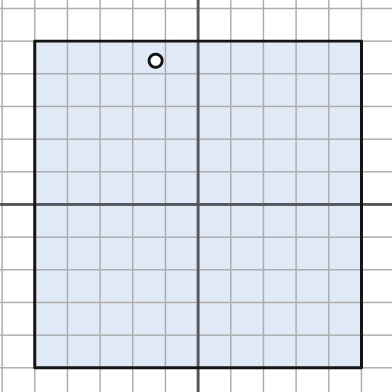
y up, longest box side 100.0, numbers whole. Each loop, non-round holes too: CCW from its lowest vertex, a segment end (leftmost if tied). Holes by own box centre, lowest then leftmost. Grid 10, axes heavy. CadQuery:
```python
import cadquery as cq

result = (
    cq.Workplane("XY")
    .moveTo(-50.0, -50.0)
    .lineTo(50.0, -50.0)
    .lineTo(50.0, 50.0)
    .lineTo(-50.0, 50.0)
    .close()
    .moveTo(-13.0, 44.0)
    .circle(2.0)
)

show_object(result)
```